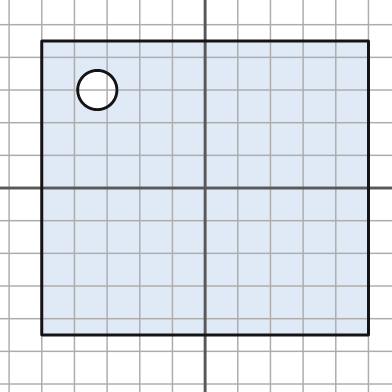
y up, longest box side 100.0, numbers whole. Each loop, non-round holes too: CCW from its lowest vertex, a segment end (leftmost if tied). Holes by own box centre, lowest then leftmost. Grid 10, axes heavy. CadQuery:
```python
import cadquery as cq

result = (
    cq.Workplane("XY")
    .moveTo(-50.0, -45.0)
    .lineTo(50.0, -45.0)
    .lineTo(50.0, 45.0)
    .lineTo(-50.0, 45.0)
    .close()
    .moveTo(-33.0, 30.0)
    .circle(6.0)
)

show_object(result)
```